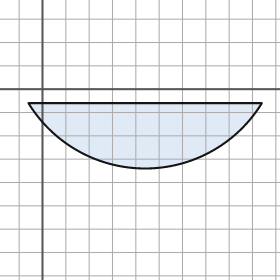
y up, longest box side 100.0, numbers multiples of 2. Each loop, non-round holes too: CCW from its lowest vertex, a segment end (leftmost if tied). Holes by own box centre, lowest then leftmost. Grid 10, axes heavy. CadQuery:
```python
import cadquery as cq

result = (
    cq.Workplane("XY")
    .moveTo(-6.0, -6.0)
    .threePointArc((44.0, -34.0), (94.0, -6.0))
    .close()
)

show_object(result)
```